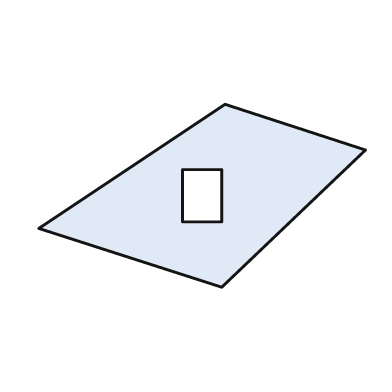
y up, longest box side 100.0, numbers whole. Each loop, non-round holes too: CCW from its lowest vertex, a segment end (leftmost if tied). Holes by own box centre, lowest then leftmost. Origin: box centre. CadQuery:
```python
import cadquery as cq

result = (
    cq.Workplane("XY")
    .moveTo(6.0, -28.0)
    .lineTo(50.0, 14.0)
    .lineTo(7.0, 28.0)
    .lineTo(-50.0, -10.0)
    .close()
    .moveTo(-6.0, -8.0)
    .lineTo(6.0, -8.0)
    .lineTo(6.0, 8.0)
    .lineTo(-6.0, 8.0)
    .close()
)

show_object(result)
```